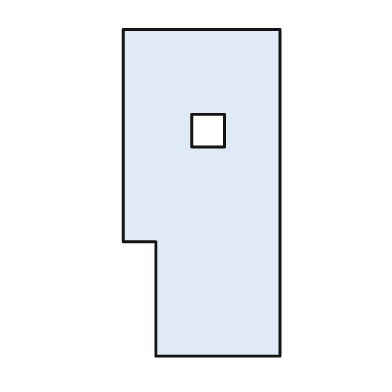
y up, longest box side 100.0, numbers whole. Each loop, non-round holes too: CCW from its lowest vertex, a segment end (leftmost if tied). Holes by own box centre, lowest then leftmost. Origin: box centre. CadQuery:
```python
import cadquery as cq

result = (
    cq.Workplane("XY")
    .moveTo(-14.0, -50.0)
    .lineTo(24.0, -50.0)
    .lineTo(24.0, 50.0)
    .lineTo(-24.0, 50.0)
    .lineTo(-24.0, -15.0)
    .lineTo(-14.0, -15.0)
    .close()
    .moveTo(-3.0, 14.0)
    .lineTo(7.0, 14.0)
    .lineTo(7.0, 24.0)
    .lineTo(-3.0, 24.0)
    .close()
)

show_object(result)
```